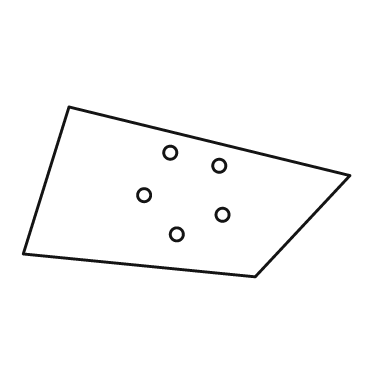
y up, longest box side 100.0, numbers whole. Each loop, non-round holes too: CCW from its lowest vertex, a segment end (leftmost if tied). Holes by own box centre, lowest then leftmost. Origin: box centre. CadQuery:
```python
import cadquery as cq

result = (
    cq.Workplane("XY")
    .moveTo(21.0, -26.0)
    .lineTo(50.0, 5.0)
    .lineTo(-36.0, 26.0)
    .lineTo(-50.0, -19.0)
    .close()
    .moveTo(-3.0, -13.0)
    .circle(2.0)
    .moveTo(11.0, -7.0)
    .circle(2.0)
    .moveTo(-13.0, -1.0)
    .circle(2.0)
    .moveTo(10.0, 8.0)
    .circle(2.0)
    .moveTo(-5.0, 12.0)
    .circle(2.0)
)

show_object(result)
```